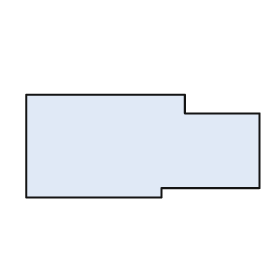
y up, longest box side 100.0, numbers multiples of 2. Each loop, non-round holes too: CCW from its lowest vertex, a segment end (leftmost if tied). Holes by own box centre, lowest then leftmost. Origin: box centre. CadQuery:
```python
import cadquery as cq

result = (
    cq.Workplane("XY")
    .moveTo(-50.0, -22.0)
    .lineTo(8.0, -22.0)
    .lineTo(8.0, -18.0)
    .lineTo(50.0, -18.0)
    .lineTo(50.0, 14.0)
    .lineTo(18.0, 14.0)
    .lineTo(18.0, 22.0)
    .lineTo(-50.0, 22.0)
    .close()
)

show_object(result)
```